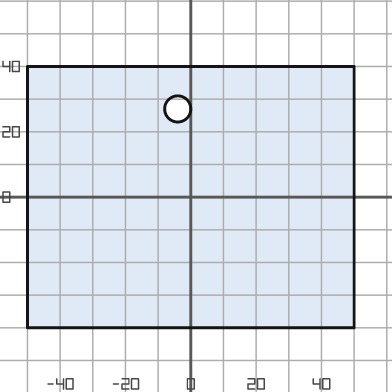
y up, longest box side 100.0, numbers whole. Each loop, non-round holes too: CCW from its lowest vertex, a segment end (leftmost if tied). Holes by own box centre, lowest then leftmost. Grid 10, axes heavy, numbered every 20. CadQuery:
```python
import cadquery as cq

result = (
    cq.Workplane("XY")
    .moveTo(-50.0, -40.0)
    .lineTo(50.0, -40.0)
    .lineTo(50.0, 40.0)
    .lineTo(-50.0, 40.0)
    .close()
    .moveTo(-4.0, 27.0)
    .circle(4.0)
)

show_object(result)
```